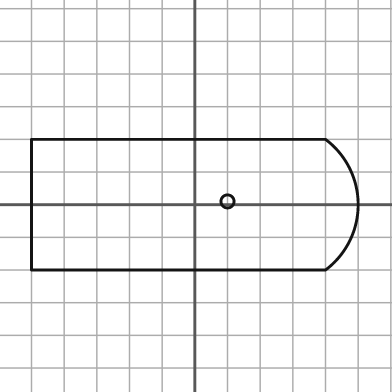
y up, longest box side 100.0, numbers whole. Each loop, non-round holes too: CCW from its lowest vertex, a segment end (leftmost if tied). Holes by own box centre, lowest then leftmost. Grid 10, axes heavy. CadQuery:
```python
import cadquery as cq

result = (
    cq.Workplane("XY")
    .moveTo(-50.0, -20.0)
    .lineTo(40.0, -20.0)
    .threePointArc((50.0, 0.0), (40.0, 20.0))
    .lineTo(-50.0, 20.0)
    .close()
    .moveTo(10.0, 1.0)
    .circle(2.0)
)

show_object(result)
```